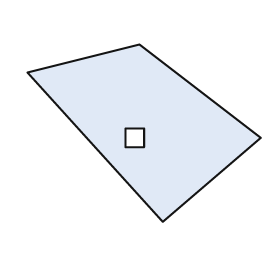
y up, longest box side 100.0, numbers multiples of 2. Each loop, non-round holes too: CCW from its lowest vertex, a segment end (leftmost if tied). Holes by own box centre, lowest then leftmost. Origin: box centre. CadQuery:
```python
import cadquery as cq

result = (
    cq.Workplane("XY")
    .moveTo(8.0, -38.0)
    .lineTo(50.0, -2.0)
    .lineTo(-2.0, 38.0)
    .lineTo(-50.0, 26.0)
    .close()
    .moveTo(-8.0, -6.0)
    .lineTo(0.0, -6.0)
    .lineTo(0.0, 2.0)
    .lineTo(-8.0, 2.0)
    .close()
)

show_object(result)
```